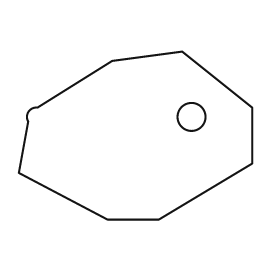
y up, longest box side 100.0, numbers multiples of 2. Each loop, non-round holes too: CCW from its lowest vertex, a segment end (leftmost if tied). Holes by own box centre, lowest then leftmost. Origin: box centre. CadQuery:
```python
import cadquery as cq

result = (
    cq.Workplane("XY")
    .moveTo(-12.0, -36.0)
    .lineTo(10.0, -36.0)
    .lineTo(50.0, -12.0)
    .lineTo(50.0, 12.0)
    .lineTo(20.0, 36.0)
    .lineTo(-10.0, 32.0)
    .lineTo(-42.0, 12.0)
    .threePointArc((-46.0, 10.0), (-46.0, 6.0))
    .lineTo(-50.0, -16.0)
    .close()
    .moveTo(24.0, 8.0)
    .circle(6.0)
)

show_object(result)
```